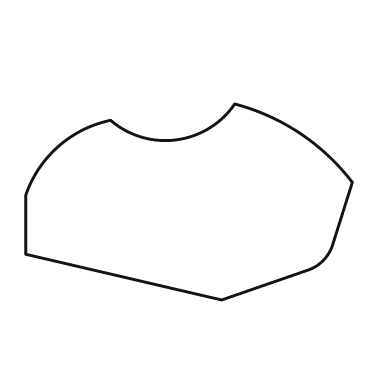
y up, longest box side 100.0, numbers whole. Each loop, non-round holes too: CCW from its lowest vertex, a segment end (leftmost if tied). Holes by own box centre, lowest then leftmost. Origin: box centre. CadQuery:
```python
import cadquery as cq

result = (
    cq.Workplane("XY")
    .moveTo(10.0, -30.0)
    .lineTo(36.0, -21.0)
    .threePointArc((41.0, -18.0), (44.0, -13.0))
    .lineTo(50.0, 6.0)
    .threePointArc((34.0, 21.0), (14.0, 30.0))
    .threePointArc((-4.0, 19.0), (-24.0, 25.0))
    .threePointArc((-40.0, 17.0), (-50.0, 2.0))
    .lineTo(-50.0, -16.0)
    .close()
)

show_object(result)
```